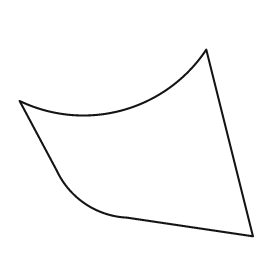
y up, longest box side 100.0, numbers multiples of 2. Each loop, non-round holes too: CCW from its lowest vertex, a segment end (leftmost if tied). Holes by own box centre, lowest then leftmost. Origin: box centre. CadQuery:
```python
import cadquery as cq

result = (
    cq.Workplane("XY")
    .moveTo(50.0, -40.0)
    .lineTo(30.0, 40.0)
    .threePointArc((-6.0, 14.0), (-50.0, 18.0))
    .lineTo(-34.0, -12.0)
    .threePointArc((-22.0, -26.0), (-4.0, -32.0))
    .close()
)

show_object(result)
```